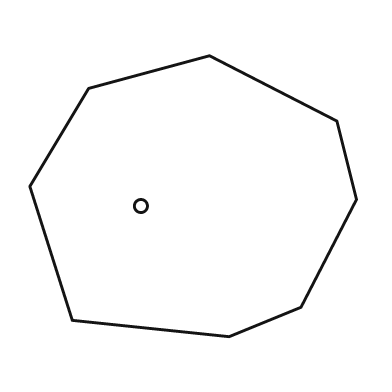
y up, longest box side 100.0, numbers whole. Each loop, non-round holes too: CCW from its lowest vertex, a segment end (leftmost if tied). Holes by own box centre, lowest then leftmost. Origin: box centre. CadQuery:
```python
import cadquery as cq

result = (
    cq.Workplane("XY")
    .moveTo(11.0, -43.0)
    .lineTo(33.0, -34.0)
    .lineTo(50.0, -1.0)
    .lineTo(44.0, 23.0)
    .lineTo(5.0, 43.0)
    .lineTo(-32.0, 33.0)
    .lineTo(-50.0, 3.0)
    .lineTo(-37.0, -38.0)
    .close()
    .moveTo(-16.0, -3.0)
    .circle(2.0)
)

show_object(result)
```